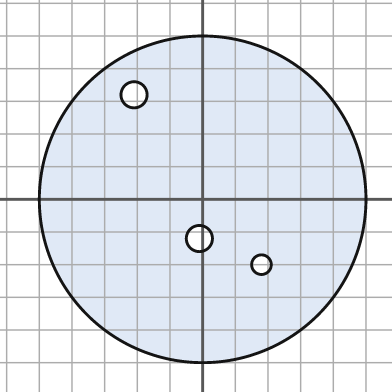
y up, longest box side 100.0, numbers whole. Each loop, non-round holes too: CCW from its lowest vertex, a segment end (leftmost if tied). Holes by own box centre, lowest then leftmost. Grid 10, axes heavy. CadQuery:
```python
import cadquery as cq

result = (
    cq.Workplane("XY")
    .moveTo(0.0, 0.0)
    .circle(50.0)
    .moveTo(18.0, -20.0)
    .circle(3.0)
    .moveTo(-1.0, -12.0)
    .circle(4.0)
    .moveTo(-21.0, 32.0)
    .circle(4.0)
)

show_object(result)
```